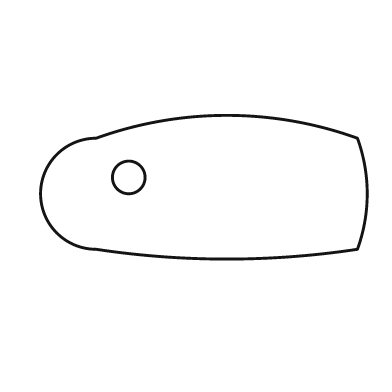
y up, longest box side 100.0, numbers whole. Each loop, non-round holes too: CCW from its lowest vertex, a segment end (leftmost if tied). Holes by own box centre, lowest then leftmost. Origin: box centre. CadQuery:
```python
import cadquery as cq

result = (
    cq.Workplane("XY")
    .moveTo(-33.0, -19.0)
    .threePointArc((7.0, -22.0), (47.0, -19.0))
    .threePointArc((50.0, -2.0), (47.0, 15.0))
    .threePointArc((7.0, 22.0), (-33.0, 15.0))
    .threePointArc((-50.0, -2.0), (-33.0, -19.0))
    .close()
    .moveTo(-23.0, 3.0)
    .circle(5.0)
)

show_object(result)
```